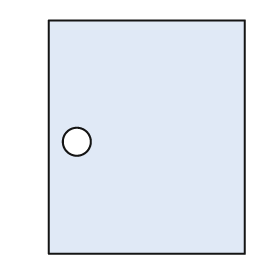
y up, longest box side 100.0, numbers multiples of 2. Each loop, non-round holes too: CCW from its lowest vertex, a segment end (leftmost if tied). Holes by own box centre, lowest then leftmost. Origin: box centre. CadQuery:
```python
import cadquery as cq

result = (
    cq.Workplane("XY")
    .moveTo(-42.0, -50.0)
    .lineTo(42.0, -50.0)
    .lineTo(42.0, 50.0)
    .lineTo(-42.0, 50.0)
    .close()
    .moveTo(-30.0, -2.0)
    .circle(6.0)
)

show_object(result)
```